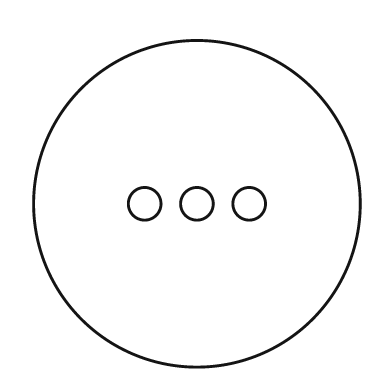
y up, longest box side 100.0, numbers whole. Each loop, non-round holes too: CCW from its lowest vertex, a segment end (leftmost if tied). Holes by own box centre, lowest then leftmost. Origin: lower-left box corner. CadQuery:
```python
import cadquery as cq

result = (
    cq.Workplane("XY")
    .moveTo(50.0, 50.0)
    .circle(50.0)
    .moveTo(34.0, 50.0)
    .circle(5.0)
    .moveTo(50.0, 50.0)
    .circle(5.0)
    .moveTo(66.0, 50.0)
    .circle(5.0)
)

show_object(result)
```